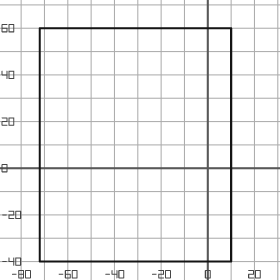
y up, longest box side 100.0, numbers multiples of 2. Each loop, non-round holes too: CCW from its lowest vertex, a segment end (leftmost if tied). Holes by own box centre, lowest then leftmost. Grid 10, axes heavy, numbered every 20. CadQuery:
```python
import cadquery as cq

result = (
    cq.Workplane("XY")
    .moveTo(-72.0, -40.0)
    .lineTo(10.0, -40.0)
    .lineTo(10.0, 60.0)
    .lineTo(-72.0, 60.0)
    .close()
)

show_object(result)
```